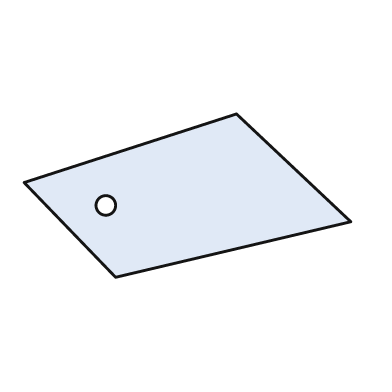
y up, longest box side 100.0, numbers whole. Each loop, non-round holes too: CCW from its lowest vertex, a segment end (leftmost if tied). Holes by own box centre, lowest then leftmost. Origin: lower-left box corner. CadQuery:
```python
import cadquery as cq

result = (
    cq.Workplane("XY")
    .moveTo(28.0, 0.0)
    .lineTo(100.0, 17.0)
    .lineTo(65.0, 50.0)
    .lineTo(0.0, 29.0)
    .close()
    .moveTo(25.0, 22.0)
    .circle(3.0)
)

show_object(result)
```